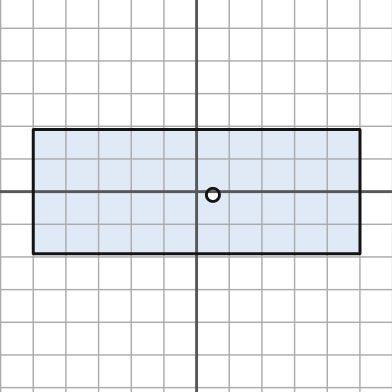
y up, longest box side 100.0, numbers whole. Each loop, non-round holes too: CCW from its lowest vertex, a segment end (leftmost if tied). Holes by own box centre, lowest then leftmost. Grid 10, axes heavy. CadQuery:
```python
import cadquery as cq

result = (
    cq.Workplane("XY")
    .moveTo(-50.0, -19.0)
    .lineTo(50.0, -19.0)
    .lineTo(50.0, 19.0)
    .lineTo(-50.0, 19.0)
    .close()
    .moveTo(5.0, -1.0)
    .circle(2.0)
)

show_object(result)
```